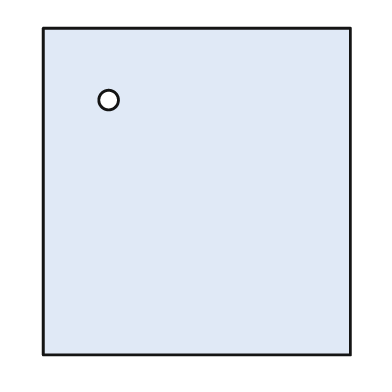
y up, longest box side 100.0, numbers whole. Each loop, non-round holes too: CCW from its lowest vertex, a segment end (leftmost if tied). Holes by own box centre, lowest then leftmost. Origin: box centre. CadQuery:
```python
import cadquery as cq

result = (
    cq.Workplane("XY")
    .moveTo(-47.0, -50.0)
    .lineTo(47.0, -50.0)
    .lineTo(47.0, 50.0)
    .lineTo(-47.0, 50.0)
    .close()
    .moveTo(-27.0, 28.0)
    .circle(3.0)
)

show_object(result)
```